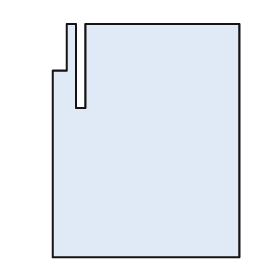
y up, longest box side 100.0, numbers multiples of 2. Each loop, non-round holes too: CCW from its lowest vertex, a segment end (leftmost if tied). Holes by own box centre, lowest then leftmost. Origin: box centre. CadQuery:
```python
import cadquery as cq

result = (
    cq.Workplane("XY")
    .moveTo(-40.0, -50.0)
    .lineTo(40.0, -50.0)
    .lineTo(40.0, 50.0)
    .lineTo(-26.0, 50.0)
    .lineTo(-26.0, 14.0)
    .lineTo(-30.0, 14.0)
    .lineTo(-30.0, 50.0)
    .lineTo(-34.0, 50.0)
    .lineTo(-34.0, 30.0)
    .lineTo(-40.0, 30.0)
    .close()
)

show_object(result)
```